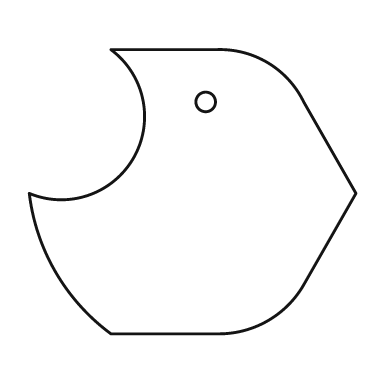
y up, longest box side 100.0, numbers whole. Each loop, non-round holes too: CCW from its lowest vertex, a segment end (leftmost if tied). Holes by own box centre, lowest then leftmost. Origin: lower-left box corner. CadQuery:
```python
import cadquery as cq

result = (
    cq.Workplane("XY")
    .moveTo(25.0, 0.0)
    .lineTo(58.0, 0.0)
    .threePointArc((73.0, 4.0), (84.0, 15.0))
    .lineTo(100.0, 43.0)
    .lineTo(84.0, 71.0)
    .threePointArc((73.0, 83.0), (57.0, 87.0))
    .lineTo(25.0, 87.0)
    .threePointArc((32.0, 54.0), (0.0, 43.0))
    .threePointArc((8.0, 19.0), (25.0, 0.0))
    .close()
    .moveTo(54.0, 71.0)
    .circle(3.0)
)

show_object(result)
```